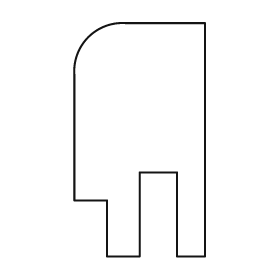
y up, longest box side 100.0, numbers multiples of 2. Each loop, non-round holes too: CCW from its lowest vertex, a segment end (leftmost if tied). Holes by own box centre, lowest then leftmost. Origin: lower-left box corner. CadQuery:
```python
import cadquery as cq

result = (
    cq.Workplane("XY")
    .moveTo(14.0, 0.0)
    .lineTo(28.0, 0.0)
    .lineTo(28.0, 36.0)
    .lineTo(44.0, 36.0)
    .lineTo(44.0, 0.0)
    .lineTo(56.0, 0.0)
    .lineTo(56.0, 100.0)
    .lineTo(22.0, 100.0)
    .threePointArc((6.0, 94.0), (0.0, 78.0))
    .lineTo(0.0, 24.0)
    .lineTo(14.0, 24.0)
    .close()
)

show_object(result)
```